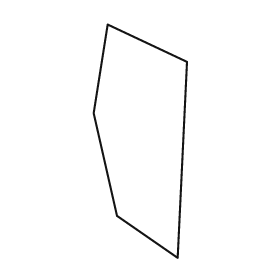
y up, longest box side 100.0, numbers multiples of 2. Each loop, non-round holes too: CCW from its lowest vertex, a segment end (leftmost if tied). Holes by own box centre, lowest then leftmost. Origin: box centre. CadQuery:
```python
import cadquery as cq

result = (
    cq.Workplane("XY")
    .moveTo(16.0, -50.0)
    .lineTo(20.0, 34.0)
    .lineTo(-14.0, 50.0)
    .lineTo(-20.0, 12.0)
    .lineTo(-10.0, -32.0)
    .close()
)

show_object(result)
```